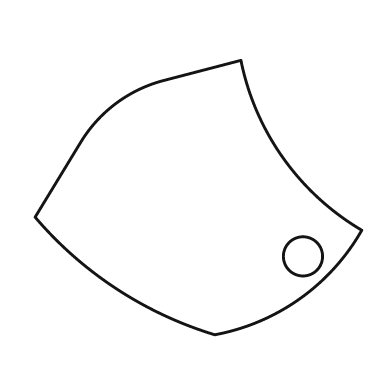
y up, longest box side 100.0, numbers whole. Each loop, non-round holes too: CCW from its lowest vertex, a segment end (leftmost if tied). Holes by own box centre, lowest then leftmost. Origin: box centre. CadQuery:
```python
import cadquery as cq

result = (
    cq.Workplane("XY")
    .moveTo(5.0, -42.0)
    .threePointArc((31.0, -31.0), (50.0, -10.0))
    .threePointArc((26.0, 12.0), (13.0, 42.0))
    .lineTo(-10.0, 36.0)
    .threePointArc((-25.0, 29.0), (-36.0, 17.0))
    .lineTo(-50.0, -6.0)
    .threePointArc((-25.0, -28.0), (5.0, -42.0))
    .close()
    .moveTo(32.0, -18.0)
    .circle(6.0)
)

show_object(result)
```